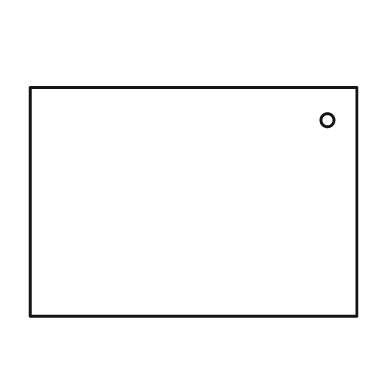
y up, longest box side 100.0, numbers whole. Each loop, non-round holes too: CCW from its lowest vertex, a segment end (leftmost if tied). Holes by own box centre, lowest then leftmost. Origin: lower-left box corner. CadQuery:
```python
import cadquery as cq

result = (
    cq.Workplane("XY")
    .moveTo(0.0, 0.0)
    .lineTo(100.0, 0.0)
    .lineTo(100.0, 70.0)
    .lineTo(0.0, 70.0)
    .close()
    .moveTo(91.0, 60.0)
    .circle(2.0)
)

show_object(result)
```